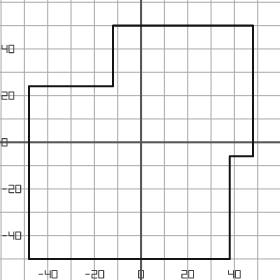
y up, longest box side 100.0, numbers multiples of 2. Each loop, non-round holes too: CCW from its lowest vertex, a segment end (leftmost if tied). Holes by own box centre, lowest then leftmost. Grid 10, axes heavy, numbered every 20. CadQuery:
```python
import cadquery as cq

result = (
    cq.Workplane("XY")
    .moveTo(-48.0, -50.0)
    .lineTo(38.0, -50.0)
    .lineTo(38.0, -6.0)
    .lineTo(48.0, -6.0)
    .lineTo(48.0, 50.0)
    .lineTo(-12.0, 50.0)
    .lineTo(-12.0, 24.0)
    .lineTo(-48.0, 24.0)
    .close()
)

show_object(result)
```